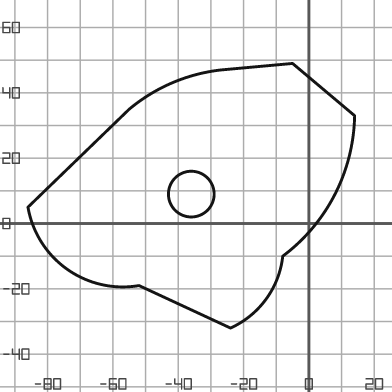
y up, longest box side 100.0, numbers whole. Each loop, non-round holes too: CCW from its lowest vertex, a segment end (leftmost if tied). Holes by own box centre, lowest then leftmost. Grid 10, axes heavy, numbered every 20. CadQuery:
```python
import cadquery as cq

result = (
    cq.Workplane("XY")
    .moveTo(-24.0, -32.0)
    .threePointArc((-13.0, -23.0), (-8.0, -10.0))
    .threePointArc((8.0, 9.0), (14.0, 33.0))
    .lineTo(-5.0, 49.0)
    .lineTo(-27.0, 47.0)
    .threePointArc((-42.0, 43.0), (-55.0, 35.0))
    .lineTo(-86.0, 5.0)
    .threePointArc((-74.0, -14.0), (-52.0, -19.0))
    .close()
    .moveTo(-36.0, 9.0)
    .circle(7.0)
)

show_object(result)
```